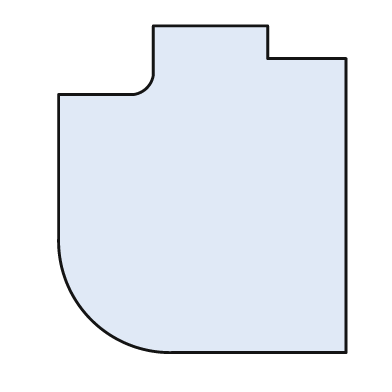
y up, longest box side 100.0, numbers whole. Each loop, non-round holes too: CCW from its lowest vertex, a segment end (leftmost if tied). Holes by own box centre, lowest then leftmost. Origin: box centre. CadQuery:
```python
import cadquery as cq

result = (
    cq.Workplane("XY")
    .moveTo(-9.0, -50.0)
    .lineTo(44.0, -50.0)
    .lineTo(44.0, 40.0)
    .lineTo(20.0, 40.0)
    .lineTo(20.0, 50.0)
    .lineTo(-15.0, 50.0)
    .lineTo(-15.0, 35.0)
    .threePointArc((-17.0, 31.0), (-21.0, 29.0))
    .lineTo(-44.0, 29.0)
    .lineTo(-44.0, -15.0)
    .threePointArc((-34.0, -40.0), (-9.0, -50.0))
    .close()
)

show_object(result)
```